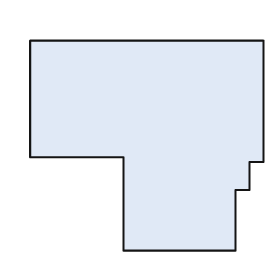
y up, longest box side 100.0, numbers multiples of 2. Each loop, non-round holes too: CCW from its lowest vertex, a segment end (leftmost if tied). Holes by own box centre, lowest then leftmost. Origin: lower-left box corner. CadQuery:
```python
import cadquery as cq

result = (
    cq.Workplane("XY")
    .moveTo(40.0, 0.0)
    .lineTo(88.0, 0.0)
    .lineTo(88.0, 26.0)
    .lineTo(94.0, 26.0)
    .lineTo(94.0, 38.0)
    .lineTo(100.0, 38.0)
    .lineTo(100.0, 90.0)
    .lineTo(0.0, 90.0)
    .lineTo(0.0, 40.0)
    .lineTo(40.0, 40.0)
    .close()
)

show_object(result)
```